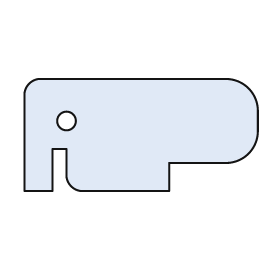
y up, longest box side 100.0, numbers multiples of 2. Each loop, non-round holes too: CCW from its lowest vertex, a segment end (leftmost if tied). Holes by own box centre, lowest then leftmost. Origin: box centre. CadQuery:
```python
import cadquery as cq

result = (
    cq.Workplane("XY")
    .moveTo(-50.0, -24.0)
    .lineTo(-38.0, -24.0)
    .lineTo(-38.0, -6.0)
    .lineTo(-32.0, -6.0)
    .lineTo(-32.0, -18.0)
    .threePointArc((-30.0, -22.0), (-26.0, -24.0))
    .lineTo(12.0, -24.0)
    .lineTo(12.0, -12.0)
    .lineTo(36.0, -12.0)
    .threePointArc((46.0, -8.0), (50.0, 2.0))
    .lineTo(50.0, 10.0)
    .threePointArc((46.0, 20.0), (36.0, 24.0))
    .lineTo(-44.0, 24.0)
    .threePointArc((-48.0, 22.0), (-50.0, 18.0))
    .close()
    .moveTo(-32.0, 6.0)
    .circle(4.0)
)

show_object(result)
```